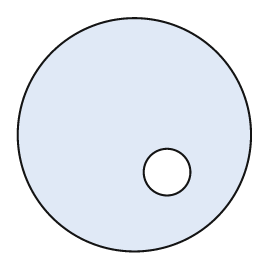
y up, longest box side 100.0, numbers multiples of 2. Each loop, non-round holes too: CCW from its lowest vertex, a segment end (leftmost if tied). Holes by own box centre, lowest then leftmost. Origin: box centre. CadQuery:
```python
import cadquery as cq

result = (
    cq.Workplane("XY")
    .moveTo(0.0, 0.0)
    .circle(50.0)
    .moveTo(14.0, -16.0)
    .circle(10.0)
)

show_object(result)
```